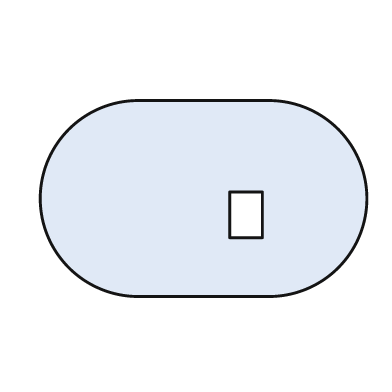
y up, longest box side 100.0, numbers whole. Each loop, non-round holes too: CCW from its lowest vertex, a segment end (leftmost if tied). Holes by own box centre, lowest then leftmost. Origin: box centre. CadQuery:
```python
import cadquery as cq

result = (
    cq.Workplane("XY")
    .moveTo(-20.0, -30.0)
    .lineTo(20.0, -30.0)
    .threePointArc((50.0, 0.0), (20.0, 30.0))
    .lineTo(-20.0, 30.0)
    .threePointArc((-50.0, 0.0), (-20.0, -30.0))
    .close()
    .moveTo(8.0, -12.0)
    .lineTo(18.0, -12.0)
    .lineTo(18.0, 2.0)
    .lineTo(8.0, 2.0)
    .close()
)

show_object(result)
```